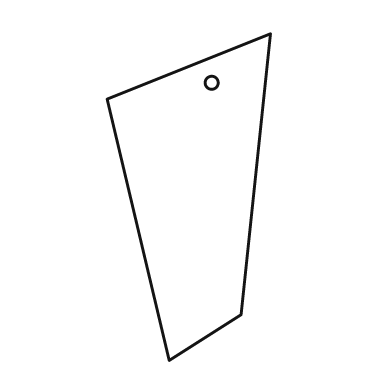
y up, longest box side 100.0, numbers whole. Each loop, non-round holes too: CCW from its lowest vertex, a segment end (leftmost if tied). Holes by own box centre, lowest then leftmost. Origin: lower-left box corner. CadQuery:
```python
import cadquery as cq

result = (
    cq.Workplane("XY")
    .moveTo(19.0, 0.0)
    .lineTo(41.0, 14.0)
    .lineTo(50.0, 100.0)
    .lineTo(0.0, 80.0)
    .close()
    .moveTo(32.0, 85.0)
    .circle(2.0)
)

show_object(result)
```